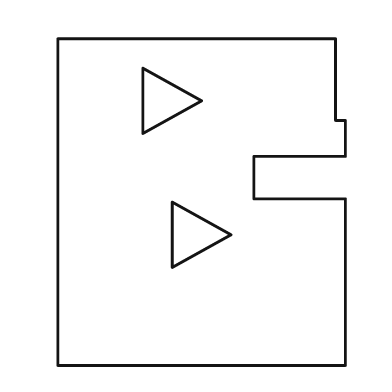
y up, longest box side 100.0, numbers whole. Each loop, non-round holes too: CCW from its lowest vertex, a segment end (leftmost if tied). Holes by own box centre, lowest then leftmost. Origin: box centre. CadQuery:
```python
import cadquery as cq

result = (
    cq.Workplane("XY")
    .moveTo(-44.0, -50.0)
    .lineTo(44.0, -50.0)
    .lineTo(44.0, 1.0)
    .lineTo(16.0, 1.0)
    .lineTo(16.0, 14.0)
    .lineTo(44.0, 14.0)
    .lineTo(44.0, 25.0)
    .lineTo(41.0, 25.0)
    .lineTo(41.0, 50.0)
    .lineTo(-44.0, 50.0)
    .close()
    .moveTo(-9.0, -20.0)
    .lineTo(9.0, -10.0)
    .lineTo(-9.0, 0.0)
    .close()
    .moveTo(-18.0, 21.0)
    .lineTo(0.0, 31.0)
    .lineTo(-18.0, 41.0)
    .close()
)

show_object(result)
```